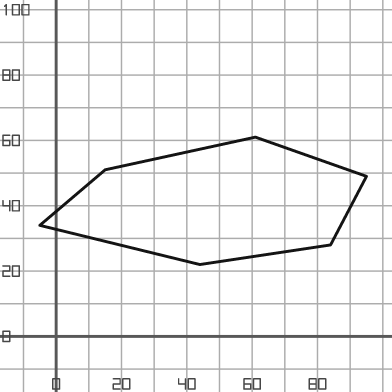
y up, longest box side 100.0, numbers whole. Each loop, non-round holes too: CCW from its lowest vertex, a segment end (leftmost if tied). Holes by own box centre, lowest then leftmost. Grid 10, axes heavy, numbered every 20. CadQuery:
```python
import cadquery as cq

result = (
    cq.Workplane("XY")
    .moveTo(44.0, 22.0)
    .lineTo(84.0, 28.0)
    .lineTo(95.0, 49.0)
    .lineTo(61.0, 61.0)
    .lineTo(15.0, 51.0)
    .lineTo(-5.0, 34.0)
    .close()
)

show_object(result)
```